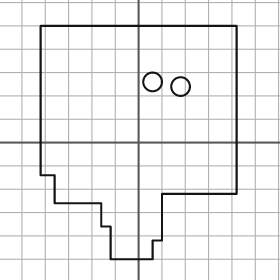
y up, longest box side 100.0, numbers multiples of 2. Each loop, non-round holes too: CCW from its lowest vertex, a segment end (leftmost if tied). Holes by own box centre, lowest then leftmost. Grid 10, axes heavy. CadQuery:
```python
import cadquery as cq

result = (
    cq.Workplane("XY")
    .moveTo(-12.0, -50.0)
    .lineTo(6.0, -50.0)
    .lineTo(6.0, -42.0)
    .lineTo(10.0, -42.0)
    .lineTo(10.0, -22.0)
    .lineTo(42.0, -22.0)
    .lineTo(42.0, 50.0)
    .lineTo(-42.0, 50.0)
    .lineTo(-42.0, -14.0)
    .lineTo(-36.0, -14.0)
    .lineTo(-36.0, -26.0)
    .lineTo(-16.0, -26.0)
    .lineTo(-16.0, -36.0)
    .lineTo(-12.0, -36.0)
    .close()
    .moveTo(18.0, 24.0)
    .circle(4.0)
    .moveTo(6.0, 26.0)
    .circle(4.0)
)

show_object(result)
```